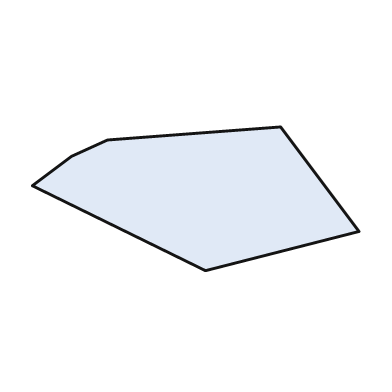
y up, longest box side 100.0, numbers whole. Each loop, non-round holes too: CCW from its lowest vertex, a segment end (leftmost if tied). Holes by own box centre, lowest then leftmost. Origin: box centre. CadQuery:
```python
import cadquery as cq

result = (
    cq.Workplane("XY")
    .moveTo(3.0, -22.0)
    .lineTo(50.0, -10.0)
    .lineTo(26.0, 22.0)
    .lineTo(-27.0, 18.0)
    .lineTo(-38.0, 13.0)
    .lineTo(-50.0, 4.0)
    .close()
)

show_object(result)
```